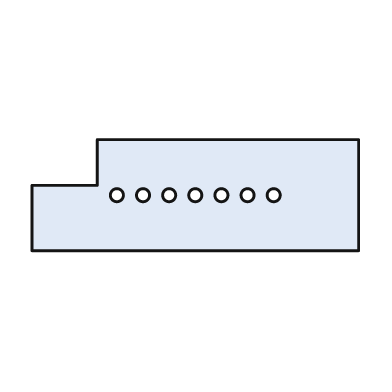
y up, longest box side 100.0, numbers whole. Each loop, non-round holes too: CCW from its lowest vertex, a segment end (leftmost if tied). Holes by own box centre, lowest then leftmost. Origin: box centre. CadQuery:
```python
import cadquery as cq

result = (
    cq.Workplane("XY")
    .moveTo(-50.0, -17.0)
    .lineTo(50.0, -17.0)
    .lineTo(50.0, 17.0)
    .lineTo(-30.0, 17.0)
    .lineTo(-30.0, 3.0)
    .lineTo(-50.0, 3.0)
    .close()
    .moveTo(-24.0, 0.0)
    .circle(2.0)
    .moveTo(-16.0, 0.0)
    .circle(2.0)
    .moveTo(-8.0, 0.0)
    .circle(2.0)
    .moveTo(0.0, 0.0)
    .circle(2.0)
    .moveTo(8.0, 0.0)
    .circle(2.0)
    .moveTo(16.0, 0.0)
    .circle(2.0)
    .moveTo(24.0, 0.0)
    .circle(2.0)
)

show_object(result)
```